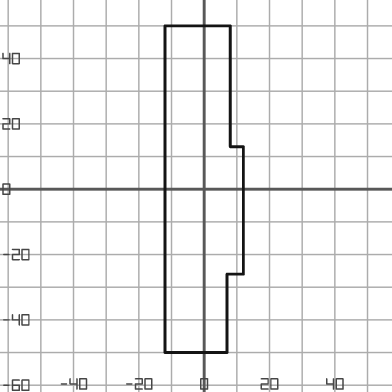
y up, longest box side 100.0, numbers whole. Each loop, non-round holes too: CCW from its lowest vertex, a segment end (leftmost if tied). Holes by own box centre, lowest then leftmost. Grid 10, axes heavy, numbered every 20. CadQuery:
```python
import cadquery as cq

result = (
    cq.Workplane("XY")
    .moveTo(-12.0, -50.0)
    .lineTo(7.0, -50.0)
    .lineTo(7.0, -26.0)
    .lineTo(12.0, -26.0)
    .lineTo(12.0, 13.0)
    .lineTo(8.0, 13.0)
    .lineTo(8.0, 50.0)
    .lineTo(-12.0, 50.0)
    .close()
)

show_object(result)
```